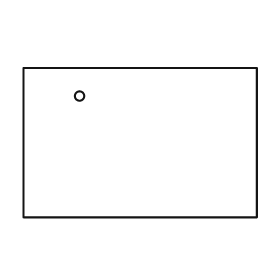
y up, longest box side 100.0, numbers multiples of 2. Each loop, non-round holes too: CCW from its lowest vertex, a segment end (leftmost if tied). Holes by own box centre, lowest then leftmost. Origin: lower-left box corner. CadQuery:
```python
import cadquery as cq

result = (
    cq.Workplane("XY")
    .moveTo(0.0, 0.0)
    .lineTo(100.0, 0.0)
    .lineTo(100.0, 64.0)
    .lineTo(0.0, 64.0)
    .close()
    .moveTo(24.0, 52.0)
    .circle(2.0)
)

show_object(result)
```